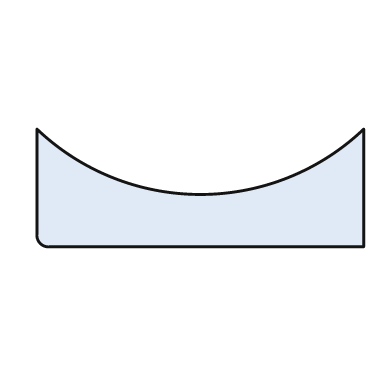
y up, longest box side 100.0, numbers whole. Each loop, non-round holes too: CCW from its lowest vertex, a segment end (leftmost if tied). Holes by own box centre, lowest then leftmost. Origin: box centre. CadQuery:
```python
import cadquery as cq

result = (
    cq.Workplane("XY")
    .moveTo(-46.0, -18.0)
    .lineTo(50.0, -18.0)
    .lineTo(50.0, 18.0)
    .threePointArc((0.0, -2.0), (-50.0, 18.0))
    .lineTo(-50.0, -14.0)
    .threePointArc((-49.0, -17.0), (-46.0, -18.0))
    .close()
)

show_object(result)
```